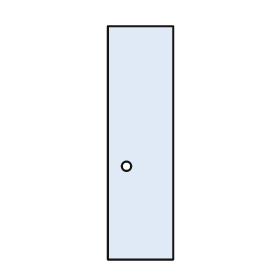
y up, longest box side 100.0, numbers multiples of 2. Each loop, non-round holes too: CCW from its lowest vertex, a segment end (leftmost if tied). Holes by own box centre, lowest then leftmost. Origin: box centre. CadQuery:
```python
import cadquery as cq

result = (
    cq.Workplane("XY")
    .moveTo(-14.0, -50.0)
    .lineTo(14.0, -50.0)
    .lineTo(14.0, 50.0)
    .lineTo(-14.0, 50.0)
    .close()
    .moveTo(-6.0, -10.0)
    .circle(2.0)
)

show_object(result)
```